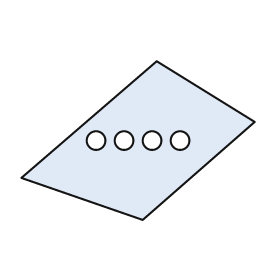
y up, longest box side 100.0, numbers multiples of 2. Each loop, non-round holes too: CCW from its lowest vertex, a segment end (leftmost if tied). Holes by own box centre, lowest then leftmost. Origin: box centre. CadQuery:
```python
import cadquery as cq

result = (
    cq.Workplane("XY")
    .moveTo(2.0, -34.0)
    .lineTo(50.0, 8.0)
    .lineTo(8.0, 34.0)
    .lineTo(-50.0, -16.0)
    .close()
    .moveTo(-18.0, 0.0)
    .circle(4.0)
    .moveTo(-6.0, 0.0)
    .circle(4.0)
    .moveTo(6.0, 0.0)
    .circle(4.0)
    .moveTo(18.0, 0.0)
    .circle(4.0)
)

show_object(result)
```